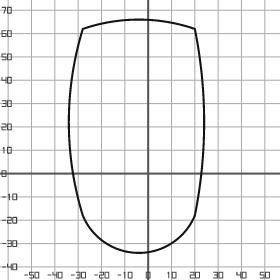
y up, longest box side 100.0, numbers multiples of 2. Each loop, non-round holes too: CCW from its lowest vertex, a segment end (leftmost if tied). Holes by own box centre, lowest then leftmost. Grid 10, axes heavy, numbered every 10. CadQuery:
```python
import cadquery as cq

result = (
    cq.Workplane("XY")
    .moveTo(-28.0, -18.0)
    .threePointArc((-4.0, -34.0), (20.0, -18.0))
    .threePointArc((24.0, 22.0), (20.0, 62.0))
    .threePointArc((-4.0, 66.0), (-28.0, 62.0))
    .threePointArc((-34.0, 22.0), (-28.0, -18.0))
    .close()
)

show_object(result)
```